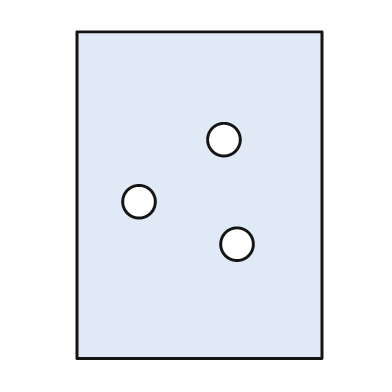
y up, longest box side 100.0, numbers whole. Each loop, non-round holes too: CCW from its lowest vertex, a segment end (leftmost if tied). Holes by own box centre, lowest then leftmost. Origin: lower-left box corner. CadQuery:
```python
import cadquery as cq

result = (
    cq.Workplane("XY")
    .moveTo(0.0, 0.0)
    .lineTo(75.0, 0.0)
    .lineTo(75.0, 100.0)
    .lineTo(0.0, 100.0)
    .close()
    .moveTo(49.0, 35.0)
    .circle(5.0)
    .moveTo(19.0, 48.0)
    .circle(5.0)
    .moveTo(45.0, 67.0)
    .circle(5.0)
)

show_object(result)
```